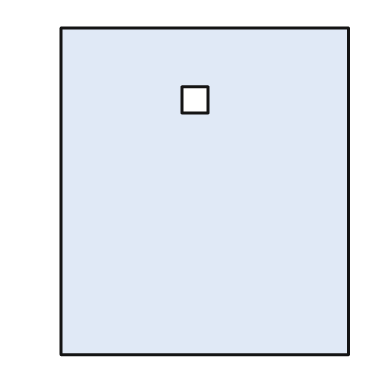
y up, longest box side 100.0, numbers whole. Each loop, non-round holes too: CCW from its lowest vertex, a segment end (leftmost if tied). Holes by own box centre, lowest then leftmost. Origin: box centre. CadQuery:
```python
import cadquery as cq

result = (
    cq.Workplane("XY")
    .moveTo(-44.0, -50.0)
    .lineTo(44.0, -50.0)
    .lineTo(44.0, 50.0)
    .lineTo(-44.0, 50.0)
    .close()
    .moveTo(-7.0, 24.0)
    .lineTo(1.0, 24.0)
    .lineTo(1.0, 32.0)
    .lineTo(-7.0, 32.0)
    .close()
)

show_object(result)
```